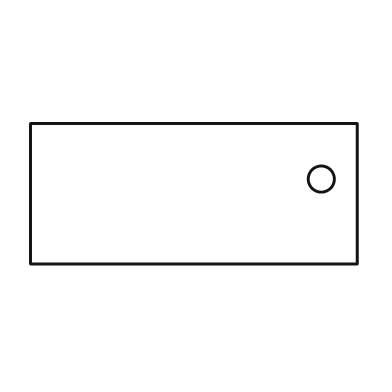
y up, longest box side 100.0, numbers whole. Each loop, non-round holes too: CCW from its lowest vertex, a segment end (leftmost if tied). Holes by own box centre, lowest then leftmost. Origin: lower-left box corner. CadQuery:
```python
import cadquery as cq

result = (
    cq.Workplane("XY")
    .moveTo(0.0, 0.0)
    .lineTo(100.0, 0.0)
    .lineTo(100.0, 43.0)
    .lineTo(0.0, 43.0)
    .close()
    .moveTo(89.0, 26.0)
    .circle(4.0)
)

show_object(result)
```